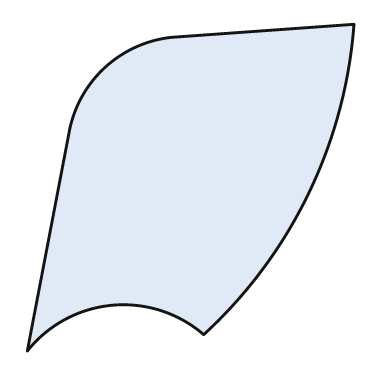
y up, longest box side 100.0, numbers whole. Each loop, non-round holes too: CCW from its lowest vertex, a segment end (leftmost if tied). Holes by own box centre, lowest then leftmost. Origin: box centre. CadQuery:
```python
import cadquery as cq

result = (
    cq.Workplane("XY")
    .moveTo(-50.0, -50.0)
    .threePointArc((-24.0, -36.0), (4.0, -45.0))
    .threePointArc((36.0, -2.0), (50.0, 50.0))
    .lineTo(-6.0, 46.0)
    .threePointArc((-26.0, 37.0), (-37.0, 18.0))
    .close()
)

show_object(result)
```